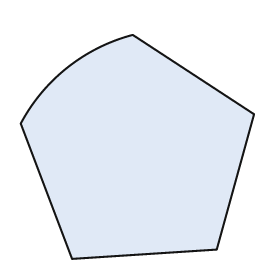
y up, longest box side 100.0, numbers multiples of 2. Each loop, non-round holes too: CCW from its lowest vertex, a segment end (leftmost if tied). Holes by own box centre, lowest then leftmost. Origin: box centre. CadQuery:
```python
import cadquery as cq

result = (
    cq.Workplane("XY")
    .moveTo(-28.0, -48.0)
    .lineTo(34.0, -44.0)
    .lineTo(50.0, 14.0)
    .lineTo(-2.0, 48.0)
    .threePointArc((-30.0, 34.0), (-50.0, 10.0))
    .close()
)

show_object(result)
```